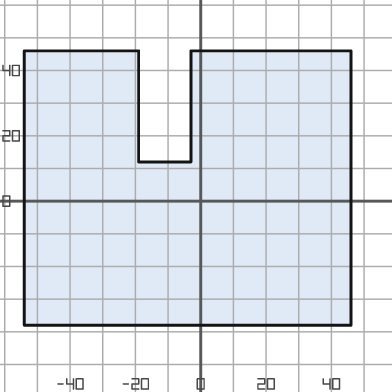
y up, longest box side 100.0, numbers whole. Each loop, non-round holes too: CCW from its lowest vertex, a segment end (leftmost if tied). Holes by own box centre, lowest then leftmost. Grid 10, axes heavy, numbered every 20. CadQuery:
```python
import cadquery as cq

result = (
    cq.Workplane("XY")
    .moveTo(-54.0, -38.0)
    .lineTo(46.0, -38.0)
    .lineTo(46.0, 46.0)
    .lineTo(-3.0, 46.0)
    .lineTo(-3.0, 12.0)
    .lineTo(-19.0, 12.0)
    .lineTo(-19.0, 46.0)
    .lineTo(-54.0, 46.0)
    .close()
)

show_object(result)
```